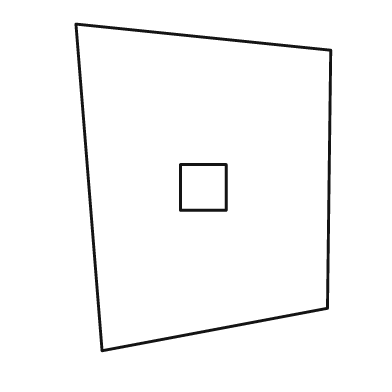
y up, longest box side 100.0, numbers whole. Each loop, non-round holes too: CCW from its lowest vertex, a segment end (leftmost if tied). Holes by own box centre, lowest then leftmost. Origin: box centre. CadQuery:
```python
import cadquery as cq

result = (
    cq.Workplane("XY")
    .moveTo(-31.0, -50.0)
    .lineTo(38.0, -37.0)
    .lineTo(39.0, 42.0)
    .lineTo(-39.0, 50.0)
    .close()
    .moveTo(-7.0, -7.0)
    .lineTo(7.0, -7.0)
    .lineTo(7.0, 7.0)
    .lineTo(-7.0, 7.0)
    .close()
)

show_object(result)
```